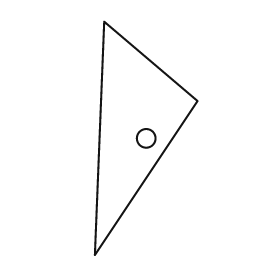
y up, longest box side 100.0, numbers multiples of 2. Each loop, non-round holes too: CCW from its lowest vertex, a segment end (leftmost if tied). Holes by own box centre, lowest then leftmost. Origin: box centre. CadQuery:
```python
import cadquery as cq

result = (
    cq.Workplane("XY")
    .moveTo(-22.0, -50.0)
    .lineTo(22.0, 16.0)
    .lineTo(-18.0, 50.0)
    .close()
    .moveTo(0.0, 0.0)
    .circle(4.0)
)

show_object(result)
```